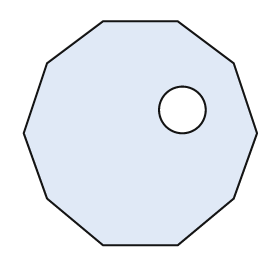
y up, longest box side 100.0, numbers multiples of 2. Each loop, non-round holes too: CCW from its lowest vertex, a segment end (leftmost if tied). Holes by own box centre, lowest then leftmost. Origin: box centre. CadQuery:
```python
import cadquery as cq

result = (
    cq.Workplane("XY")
    .moveTo(-16.0, -48.0)
    .lineTo(16.0, -48.0)
    .lineTo(40.0, -28.0)
    .lineTo(50.0, 0.0)
    .lineTo(40.0, 30.0)
    .lineTo(16.0, 48.0)
    .lineTo(-16.0, 48.0)
    .lineTo(-40.0, 30.0)
    .lineTo(-50.0, 0.0)
    .lineTo(-40.0, -28.0)
    .close()
    .moveTo(18.0, 10.0)
    .circle(10.0)
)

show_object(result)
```